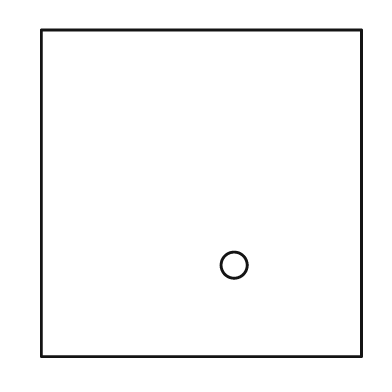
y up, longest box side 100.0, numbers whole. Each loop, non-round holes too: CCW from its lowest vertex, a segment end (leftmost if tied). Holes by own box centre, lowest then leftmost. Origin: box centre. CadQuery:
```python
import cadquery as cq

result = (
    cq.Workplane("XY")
    .moveTo(-49.0, -50.0)
    .lineTo(49.0, -50.0)
    .lineTo(49.0, 50.0)
    .lineTo(-49.0, 50.0)
    .close()
    .moveTo(10.0, -22.0)
    .circle(4.0)
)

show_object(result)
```